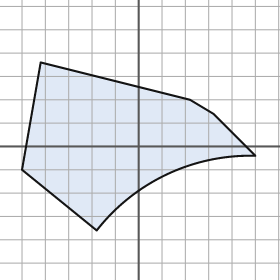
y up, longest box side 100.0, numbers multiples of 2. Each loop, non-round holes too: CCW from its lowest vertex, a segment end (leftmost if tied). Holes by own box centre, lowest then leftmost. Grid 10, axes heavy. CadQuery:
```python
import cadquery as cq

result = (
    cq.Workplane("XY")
    .moveTo(-18.0, -36.0)
    .threePointArc((12.0, -12.0), (50.0, -4.0))
    .lineTo(32.0, 14.0)
    .lineTo(22.0, 20.0)
    .lineTo(-42.0, 36.0)
    .lineTo(-50.0, -10.0)
    .close()
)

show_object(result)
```